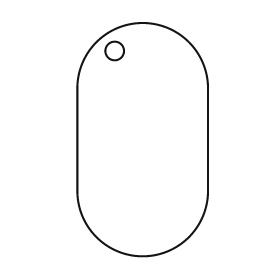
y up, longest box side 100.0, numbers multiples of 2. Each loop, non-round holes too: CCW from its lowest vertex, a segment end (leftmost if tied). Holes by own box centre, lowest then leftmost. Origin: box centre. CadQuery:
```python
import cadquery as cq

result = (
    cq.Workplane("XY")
    .moveTo(-28.0, -22.0)
    .threePointArc((0.0, -50.0), (28.0, -22.0))
    .lineTo(28.0, 22.0)
    .threePointArc((0.0, 50.0), (-28.0, 22.0))
    .close()
    .moveTo(-12.0, 38.0)
    .circle(4.0)
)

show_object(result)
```